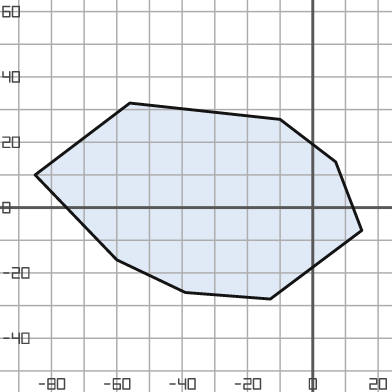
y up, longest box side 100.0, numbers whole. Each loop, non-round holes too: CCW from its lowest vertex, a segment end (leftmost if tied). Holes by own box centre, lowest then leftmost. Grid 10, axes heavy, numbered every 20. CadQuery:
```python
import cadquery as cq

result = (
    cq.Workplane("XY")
    .moveTo(-13.0, -28.0)
    .lineTo(15.0, -7.0)
    .lineTo(7.0, 14.0)
    .lineTo(-10.0, 27.0)
    .lineTo(-56.0, 32.0)
    .lineTo(-85.0, 10.0)
    .lineTo(-60.0, -16.0)
    .lineTo(-39.0, -26.0)
    .close()
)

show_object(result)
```